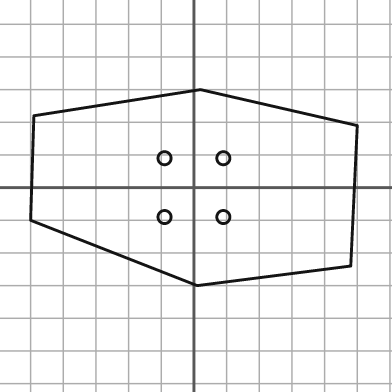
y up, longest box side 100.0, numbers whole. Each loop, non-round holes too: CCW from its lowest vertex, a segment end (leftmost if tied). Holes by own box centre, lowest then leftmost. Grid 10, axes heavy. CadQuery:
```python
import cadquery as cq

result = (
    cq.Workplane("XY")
    .moveTo(1.0, -30.0)
    .lineTo(48.0, -24.0)
    .lineTo(50.0, 19.0)
    .lineTo(2.0, 30.0)
    .lineTo(-49.0, 22.0)
    .lineTo(-50.0, -10.0)
    .close()
    .moveTo(-9.0, -9.0)
    .circle(2.0)
    .moveTo(9.0, -9.0)
    .circle(2.0)
    .moveTo(-9.0, 9.0)
    .circle(2.0)
    .moveTo(9.0, 9.0)
    .circle(2.0)
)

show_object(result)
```